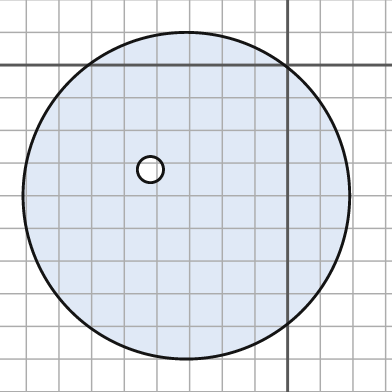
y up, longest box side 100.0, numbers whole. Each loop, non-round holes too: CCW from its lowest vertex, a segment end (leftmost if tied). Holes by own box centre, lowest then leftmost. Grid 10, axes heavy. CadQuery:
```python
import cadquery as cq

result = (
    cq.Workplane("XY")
    .moveTo(-31.0, -40.0)
    .circle(50.0)
    .moveTo(-42.0, -32.0)
    .circle(4.0)
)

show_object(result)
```